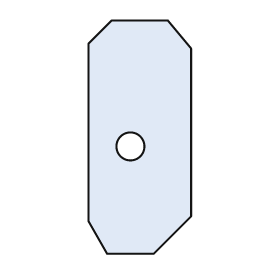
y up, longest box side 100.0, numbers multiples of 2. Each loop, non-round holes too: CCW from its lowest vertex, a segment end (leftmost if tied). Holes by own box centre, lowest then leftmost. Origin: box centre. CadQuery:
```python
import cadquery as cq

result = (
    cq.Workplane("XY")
    .moveTo(-14.0, -50.0)
    .lineTo(6.0, -50.0)
    .lineTo(22.0, -34.0)
    .lineTo(22.0, 38.0)
    .lineTo(12.0, 50.0)
    .lineTo(-12.0, 50.0)
    .lineTo(-22.0, 40.0)
    .lineTo(-22.0, -36.0)
    .close()
    .moveTo(-4.0, -4.0)
    .circle(6.0)
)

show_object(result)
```